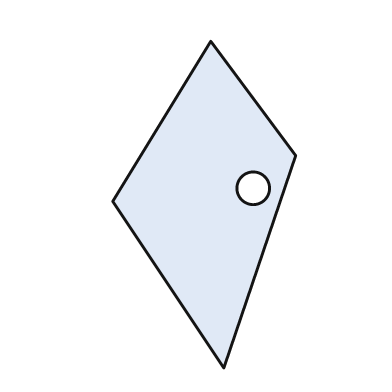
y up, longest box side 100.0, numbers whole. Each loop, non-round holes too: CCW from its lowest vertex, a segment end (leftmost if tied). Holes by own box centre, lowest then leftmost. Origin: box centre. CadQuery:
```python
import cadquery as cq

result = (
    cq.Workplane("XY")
    .moveTo(6.0, -50.0)
    .lineTo(28.0, 15.0)
    .lineTo(2.0, 50.0)
    .lineTo(-28.0, 1.0)
    .close()
    .moveTo(15.0, 5.0)
    .circle(5.0)
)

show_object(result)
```